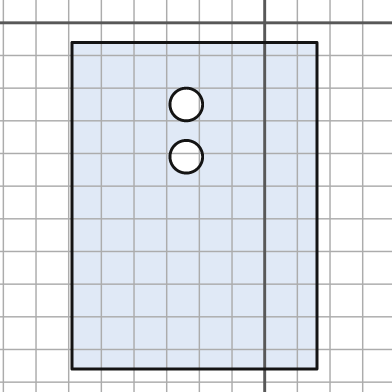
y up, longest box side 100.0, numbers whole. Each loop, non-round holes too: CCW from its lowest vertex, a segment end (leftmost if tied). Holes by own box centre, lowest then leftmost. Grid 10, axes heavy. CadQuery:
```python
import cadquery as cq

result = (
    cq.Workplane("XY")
    .moveTo(-59.0, -106.0)
    .lineTo(16.0, -106.0)
    .lineTo(16.0, -6.0)
    .lineTo(-59.0, -6.0)
    .close()
    .moveTo(-24.0, -41.0)
    .circle(5.0)
    .moveTo(-24.0, -25.0)
    .circle(5.0)
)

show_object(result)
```